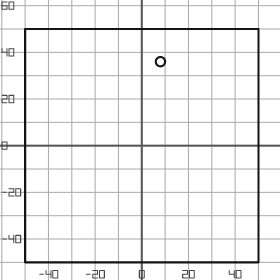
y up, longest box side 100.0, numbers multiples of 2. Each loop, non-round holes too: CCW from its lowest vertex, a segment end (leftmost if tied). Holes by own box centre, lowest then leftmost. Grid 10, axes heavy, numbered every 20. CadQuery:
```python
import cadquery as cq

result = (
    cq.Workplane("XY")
    .moveTo(-50.0, -50.0)
    .lineTo(50.0, -50.0)
    .lineTo(50.0, 50.0)
    .lineTo(-50.0, 50.0)
    .close()
    .moveTo(8.0, 36.0)
    .circle(2.0)
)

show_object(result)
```